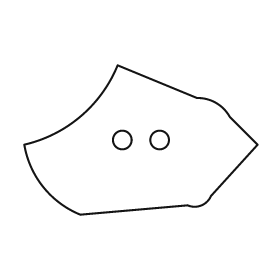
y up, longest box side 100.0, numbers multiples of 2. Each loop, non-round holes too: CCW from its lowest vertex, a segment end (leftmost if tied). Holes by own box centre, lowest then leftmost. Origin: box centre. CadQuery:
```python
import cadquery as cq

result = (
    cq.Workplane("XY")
    .moveTo(-26.0, -32.0)
    .lineTo(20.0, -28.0)
    .threePointArc((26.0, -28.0), (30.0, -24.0))
    .lineTo(50.0, -2.0)
    .lineTo(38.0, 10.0)
    .threePointArc((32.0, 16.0), (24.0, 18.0))
    .lineTo(-10.0, 32.0)
    .threePointArc((-26.0, 10.0), (-50.0, -2.0))
    .threePointArc((-42.0, -20.0), (-26.0, -32.0))
    .close()
    .moveTo(-8.0, 0.0)
    .circle(4.0)
    .moveTo(8.0, 0.0)
    .circle(4.0)
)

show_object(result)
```